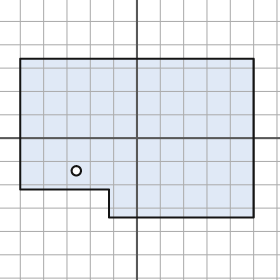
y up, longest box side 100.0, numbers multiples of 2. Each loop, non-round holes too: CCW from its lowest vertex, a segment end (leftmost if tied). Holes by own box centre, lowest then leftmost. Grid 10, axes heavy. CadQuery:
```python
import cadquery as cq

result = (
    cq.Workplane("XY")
    .moveTo(-12.0, -34.0)
    .lineTo(50.0, -34.0)
    .lineTo(50.0, 34.0)
    .lineTo(-50.0, 34.0)
    .lineTo(-50.0, -22.0)
    .lineTo(-12.0, -22.0)
    .close()
    .moveTo(-26.0, -14.0)
    .circle(2.0)
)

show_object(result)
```